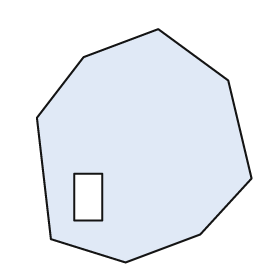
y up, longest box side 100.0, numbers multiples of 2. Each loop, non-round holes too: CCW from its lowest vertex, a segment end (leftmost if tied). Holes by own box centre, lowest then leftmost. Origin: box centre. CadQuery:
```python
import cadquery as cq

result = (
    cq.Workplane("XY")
    .moveTo(-8.0, -50.0)
    .lineTo(24.0, -38.0)
    .lineTo(46.0, -14.0)
    .lineTo(36.0, 28.0)
    .lineTo(6.0, 50.0)
    .lineTo(-26.0, 38.0)
    .lineTo(-46.0, 12.0)
    .lineTo(-40.0, -40.0)
    .close()
    .moveTo(-30.0, -32.0)
    .lineTo(-18.0, -32.0)
    .lineTo(-18.0, -12.0)
    .lineTo(-30.0, -12.0)
    .close()
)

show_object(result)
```